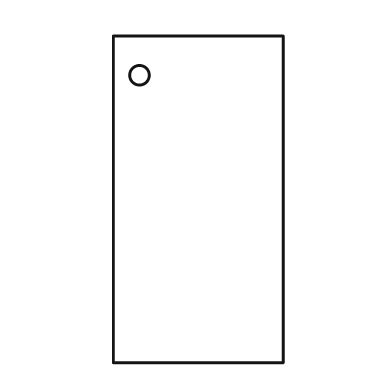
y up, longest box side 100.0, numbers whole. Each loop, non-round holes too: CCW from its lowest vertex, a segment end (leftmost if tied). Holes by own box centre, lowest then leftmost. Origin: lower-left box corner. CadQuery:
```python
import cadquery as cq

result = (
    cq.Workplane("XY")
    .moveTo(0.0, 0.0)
    .lineTo(52.0, 0.0)
    .lineTo(52.0, 100.0)
    .lineTo(0.0, 100.0)
    .close()
    .moveTo(8.0, 88.0)
    .circle(3.0)
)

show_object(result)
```